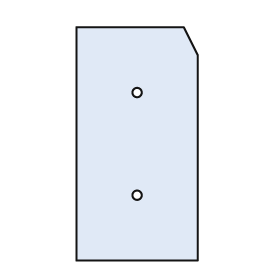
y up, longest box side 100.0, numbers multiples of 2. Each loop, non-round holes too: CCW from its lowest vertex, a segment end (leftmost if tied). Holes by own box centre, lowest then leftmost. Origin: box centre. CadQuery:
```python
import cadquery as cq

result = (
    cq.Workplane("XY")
    .moveTo(-26.0, -50.0)
    .lineTo(26.0, -50.0)
    .lineTo(26.0, 38.0)
    .lineTo(20.0, 50.0)
    .lineTo(-26.0, 50.0)
    .close()
    .moveTo(0.0, -22.0)
    .circle(2.0)
    .moveTo(0.0, 22.0)
    .circle(2.0)
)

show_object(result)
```